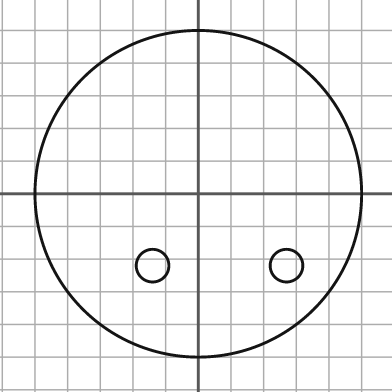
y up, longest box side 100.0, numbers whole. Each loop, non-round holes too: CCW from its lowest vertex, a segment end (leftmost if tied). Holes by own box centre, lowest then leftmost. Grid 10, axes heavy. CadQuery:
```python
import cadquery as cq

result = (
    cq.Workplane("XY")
    .moveTo(0.0, 0.0)
    .circle(50.0)
    .moveTo(-14.0, -22.0)
    .circle(5.0)
    .moveTo(27.0, -22.0)
    .circle(5.0)
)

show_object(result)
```